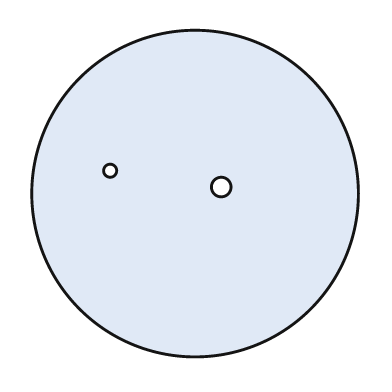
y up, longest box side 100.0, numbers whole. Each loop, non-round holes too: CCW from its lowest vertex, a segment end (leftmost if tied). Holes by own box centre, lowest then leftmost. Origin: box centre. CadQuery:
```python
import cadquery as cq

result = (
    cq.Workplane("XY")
    .moveTo(0.0, 0.0)
    .circle(50.0)
    .moveTo(8.0, 2.0)
    .circle(3.0)
    .moveTo(-26.0, 7.0)
    .circle(2.0)
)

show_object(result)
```